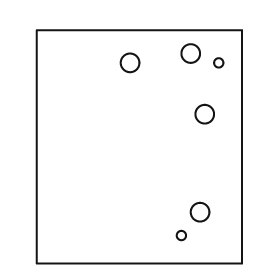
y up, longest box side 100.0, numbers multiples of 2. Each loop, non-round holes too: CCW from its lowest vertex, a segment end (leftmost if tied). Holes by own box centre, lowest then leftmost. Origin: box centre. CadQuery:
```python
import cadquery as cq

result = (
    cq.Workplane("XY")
    .moveTo(-44.0, -50.0)
    .lineTo(44.0, -50.0)
    .lineTo(44.0, 50.0)
    .lineTo(-44.0, 50.0)
    .close()
    .moveTo(18.0, -38.0)
    .circle(2.0)
    .moveTo(26.0, -28.0)
    .circle(4.0)
    .moveTo(28.0, 14.0)
    .circle(4.0)
    .moveTo(-4.0, 36.0)
    .circle(4.0)
    .moveTo(34.0, 36.0)
    .circle(2.0)
    .moveTo(22.0, 40.0)
    .circle(4.0)
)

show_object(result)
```